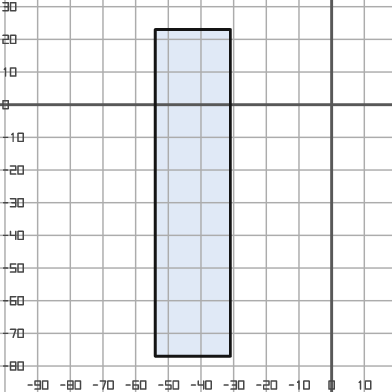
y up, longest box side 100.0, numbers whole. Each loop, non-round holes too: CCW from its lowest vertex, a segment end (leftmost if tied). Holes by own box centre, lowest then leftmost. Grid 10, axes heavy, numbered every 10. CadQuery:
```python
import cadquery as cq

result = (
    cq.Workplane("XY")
    .moveTo(-54.0, -77.0)
    .lineTo(-31.0, -77.0)
    .lineTo(-31.0, 23.0)
    .lineTo(-54.0, 23.0)
    .close()
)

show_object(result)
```